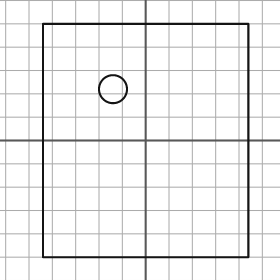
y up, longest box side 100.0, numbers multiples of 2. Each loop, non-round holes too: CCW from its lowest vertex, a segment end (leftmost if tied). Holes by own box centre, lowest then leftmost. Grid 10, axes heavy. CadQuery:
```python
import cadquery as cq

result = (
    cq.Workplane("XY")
    .moveTo(-44.0, -50.0)
    .lineTo(44.0, -50.0)
    .lineTo(44.0, 50.0)
    .lineTo(-44.0, 50.0)
    .close()
    .moveTo(-14.0, 22.0)
    .circle(6.0)
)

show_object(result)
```